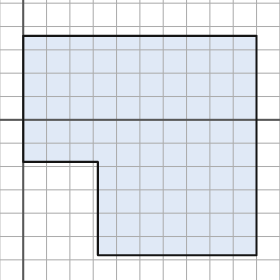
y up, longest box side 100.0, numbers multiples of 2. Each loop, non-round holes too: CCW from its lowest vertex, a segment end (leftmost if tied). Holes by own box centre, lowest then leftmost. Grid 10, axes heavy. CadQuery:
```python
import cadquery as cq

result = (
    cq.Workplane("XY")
    .moveTo(32.0, -58.0)
    .lineTo(100.0, -58.0)
    .lineTo(100.0, 36.0)
    .lineTo(0.0, 36.0)
    .lineTo(0.0, -18.0)
    .lineTo(32.0, -18.0)
    .close()
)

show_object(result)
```